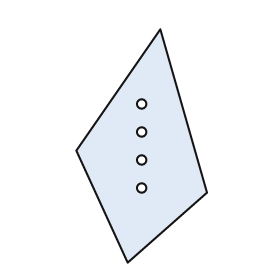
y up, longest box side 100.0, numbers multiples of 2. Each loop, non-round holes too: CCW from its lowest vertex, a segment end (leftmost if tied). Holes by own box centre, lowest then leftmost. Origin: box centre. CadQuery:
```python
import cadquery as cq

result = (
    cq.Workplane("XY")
    .moveTo(-6.0, -50.0)
    .lineTo(28.0, -20.0)
    .lineTo(8.0, 50.0)
    .lineTo(-28.0, -2.0)
    .close()
    .moveTo(0.0, -18.0)
    .circle(2.0)
    .moveTo(0.0, -6.0)
    .circle(2.0)
    .moveTo(0.0, 6.0)
    .circle(2.0)
    .moveTo(0.0, 18.0)
    .circle(2.0)
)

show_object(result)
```